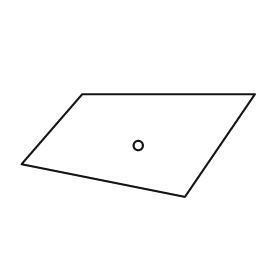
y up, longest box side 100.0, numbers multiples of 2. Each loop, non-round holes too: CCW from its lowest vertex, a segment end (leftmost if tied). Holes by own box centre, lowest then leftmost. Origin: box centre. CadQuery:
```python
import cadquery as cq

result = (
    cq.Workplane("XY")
    .moveTo(20.0, -22.0)
    .lineTo(50.0, 22.0)
    .lineTo(-24.0, 22.0)
    .lineTo(-50.0, -8.0)
    .close()
    .moveTo(0.0, 0.0)
    .circle(2.0)
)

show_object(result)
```